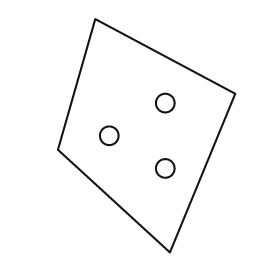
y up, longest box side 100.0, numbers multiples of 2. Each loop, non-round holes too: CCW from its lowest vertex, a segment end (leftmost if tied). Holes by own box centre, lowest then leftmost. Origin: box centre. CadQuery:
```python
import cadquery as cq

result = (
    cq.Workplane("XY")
    .moveTo(10.0, -50.0)
    .lineTo(38.0, 18.0)
    .lineTo(-22.0, 50.0)
    .lineTo(-38.0, -6.0)
    .close()
    .moveTo(8.0, -14.0)
    .circle(4.0)
    .moveTo(-16.0, 0.0)
    .circle(4.0)
    .moveTo(8.0, 14.0)
    .circle(4.0)
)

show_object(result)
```